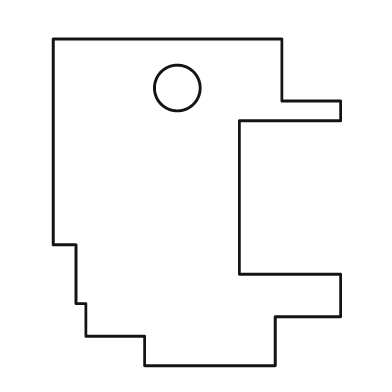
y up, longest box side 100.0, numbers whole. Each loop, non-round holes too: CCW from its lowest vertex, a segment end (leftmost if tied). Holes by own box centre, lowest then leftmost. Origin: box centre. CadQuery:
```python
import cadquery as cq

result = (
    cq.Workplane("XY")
    .moveTo(-16.0, -50.0)
    .lineTo(24.0, -50.0)
    .lineTo(24.0, -35.0)
    .lineTo(44.0, -35.0)
    .lineTo(44.0, -22.0)
    .lineTo(13.0, -22.0)
    .lineTo(13.0, 25.0)
    .lineTo(44.0, 25.0)
    .lineTo(44.0, 31.0)
    .lineTo(26.0, 31.0)
    .lineTo(26.0, 50.0)
    .lineTo(-44.0, 50.0)
    .lineTo(-44.0, -13.0)
    .lineTo(-37.0, -13.0)
    .lineTo(-37.0, -31.0)
    .lineTo(-34.0, -31.0)
    .lineTo(-34.0, -41.0)
    .lineTo(-16.0, -41.0)
    .close()
    .moveTo(-6.0, 35.0)
    .circle(7.0)
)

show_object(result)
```